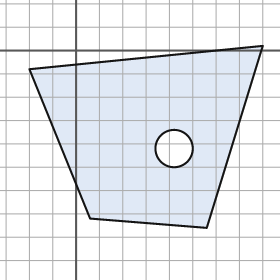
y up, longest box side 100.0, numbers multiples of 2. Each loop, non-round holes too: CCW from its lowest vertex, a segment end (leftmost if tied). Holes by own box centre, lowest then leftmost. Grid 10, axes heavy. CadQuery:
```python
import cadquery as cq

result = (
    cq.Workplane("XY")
    .moveTo(56.0, -76.0)
    .lineTo(80.0, 2.0)
    .lineTo(-20.0, -8.0)
    .lineTo(6.0, -72.0)
    .close()
    .moveTo(42.0, -42.0)
    .circle(8.0)
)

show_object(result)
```